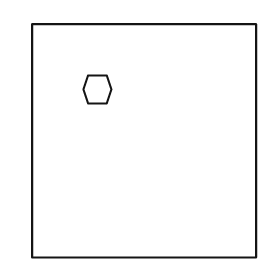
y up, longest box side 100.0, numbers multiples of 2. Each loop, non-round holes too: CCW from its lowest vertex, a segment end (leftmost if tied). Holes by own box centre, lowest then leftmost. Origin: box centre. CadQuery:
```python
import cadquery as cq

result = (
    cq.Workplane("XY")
    .moveTo(-48.0, -50.0)
    .lineTo(48.0, -50.0)
    .lineTo(48.0, 50.0)
    .lineTo(-48.0, 50.0)
    .close()
    .moveTo(-24.0, 16.0)
    .lineTo(-16.0, 16.0)
    .lineTo(-14.0, 22.0)
    .lineTo(-16.0, 28.0)
    .lineTo(-24.0, 28.0)
    .lineTo(-26.0, 22.0)
    .close()
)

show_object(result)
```